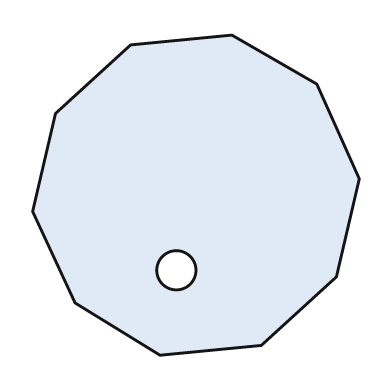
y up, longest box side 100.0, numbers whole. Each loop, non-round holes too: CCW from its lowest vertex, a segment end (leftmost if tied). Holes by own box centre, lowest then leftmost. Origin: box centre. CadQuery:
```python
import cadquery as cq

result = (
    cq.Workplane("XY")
    .moveTo(-11.0, -49.0)
    .lineTo(20.0, -46.0)
    .lineTo(43.0, -25.0)
    .lineTo(50.0, 5.0)
    .lineTo(37.0, 34.0)
    .lineTo(11.0, 49.0)
    .lineTo(-20.0, 46.0)
    .lineTo(-43.0, 25.0)
    .lineTo(-50.0, -5.0)
    .lineTo(-37.0, -33.0)
    .close()
    .moveTo(-6.0, -23.0)
    .circle(6.0)
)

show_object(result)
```